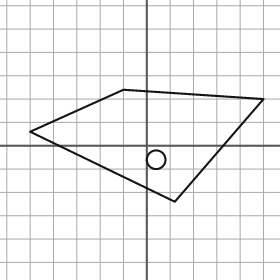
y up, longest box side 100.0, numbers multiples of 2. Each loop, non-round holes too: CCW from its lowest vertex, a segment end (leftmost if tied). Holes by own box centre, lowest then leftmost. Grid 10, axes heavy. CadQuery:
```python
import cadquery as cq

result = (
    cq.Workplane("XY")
    .moveTo(12.0, -24.0)
    .lineTo(50.0, 20.0)
    .lineTo(-10.0, 24.0)
    .lineTo(-50.0, 6.0)
    .close()
    .moveTo(4.0, -6.0)
    .circle(4.0)
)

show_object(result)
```